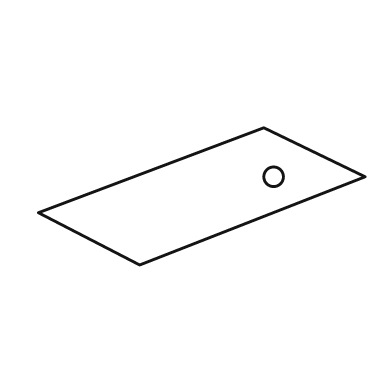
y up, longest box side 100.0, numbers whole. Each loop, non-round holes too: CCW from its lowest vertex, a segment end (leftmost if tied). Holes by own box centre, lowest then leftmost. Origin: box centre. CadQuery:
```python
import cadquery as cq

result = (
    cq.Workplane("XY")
    .moveTo(-19.0, -21.0)
    .lineTo(50.0, 6.0)
    .lineTo(19.0, 21.0)
    .lineTo(-50.0, -5.0)
    .close()
    .moveTo(22.0, 6.0)
    .circle(3.0)
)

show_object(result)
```